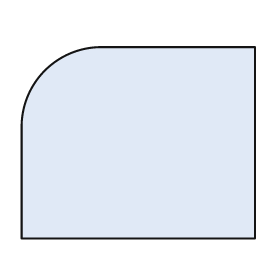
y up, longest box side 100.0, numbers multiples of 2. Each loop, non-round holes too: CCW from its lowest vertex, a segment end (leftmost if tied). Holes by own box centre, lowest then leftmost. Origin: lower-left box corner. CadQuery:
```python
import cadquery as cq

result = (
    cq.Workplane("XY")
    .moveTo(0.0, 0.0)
    .lineTo(100.0, 0.0)
    .lineTo(100.0, 82.0)
    .lineTo(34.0, 82.0)
    .threePointArc((10.0, 72.0), (0.0, 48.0))
    .close()
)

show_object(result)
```